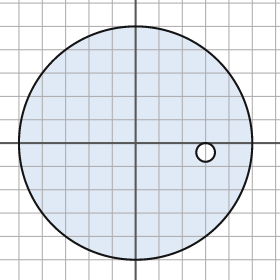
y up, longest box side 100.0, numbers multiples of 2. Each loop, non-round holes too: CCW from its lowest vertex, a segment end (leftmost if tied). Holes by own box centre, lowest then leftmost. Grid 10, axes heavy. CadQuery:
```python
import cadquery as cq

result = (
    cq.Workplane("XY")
    .moveTo(0.0, 0.0)
    .circle(50.0)
    .moveTo(30.0, -4.0)
    .circle(4.0)
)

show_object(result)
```